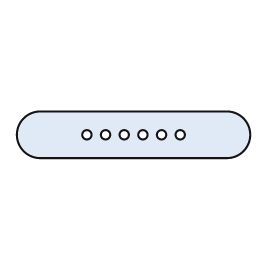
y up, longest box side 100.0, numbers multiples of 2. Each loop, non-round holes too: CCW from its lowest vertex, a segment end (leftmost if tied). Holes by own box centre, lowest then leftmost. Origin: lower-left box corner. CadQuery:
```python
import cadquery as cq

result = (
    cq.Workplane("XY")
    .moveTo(10.0, 0.0)
    .lineTo(90.0, 0.0)
    .threePointArc((100.0, 10.0), (90.0, 20.0))
    .lineTo(10.0, 20.0)
    .threePointArc((0.0, 10.0), (10.0, 0.0))
    .close()
    .moveTo(30.0, 10.0)
    .circle(2.0)
    .moveTo(38.0, 10.0)
    .circle(2.0)
    .moveTo(46.0, 10.0)
    .circle(2.0)
    .moveTo(54.0, 10.0)
    .circle(2.0)
    .moveTo(62.0, 10.0)
    .circle(2.0)
    .moveTo(70.0, 10.0)
    .circle(2.0)
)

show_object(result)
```